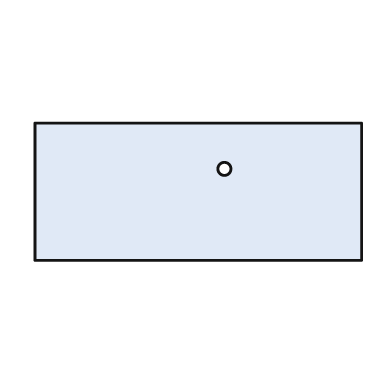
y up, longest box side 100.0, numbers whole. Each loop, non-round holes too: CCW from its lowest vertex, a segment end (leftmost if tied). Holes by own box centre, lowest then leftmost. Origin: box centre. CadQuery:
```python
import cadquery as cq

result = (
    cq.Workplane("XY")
    .moveTo(-50.0, -21.0)
    .lineTo(50.0, -21.0)
    .lineTo(50.0, 21.0)
    .lineTo(-50.0, 21.0)
    .close()
    .moveTo(8.0, 7.0)
    .circle(2.0)
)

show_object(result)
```